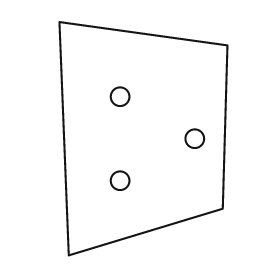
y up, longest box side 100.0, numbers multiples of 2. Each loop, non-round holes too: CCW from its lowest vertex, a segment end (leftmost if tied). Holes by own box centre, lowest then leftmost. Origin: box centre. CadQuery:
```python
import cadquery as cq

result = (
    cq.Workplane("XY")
    .moveTo(-32.0, -50.0)
    .lineTo(34.0, -30.0)
    .lineTo(36.0, 40.0)
    .lineTo(-36.0, 50.0)
    .close()
    .moveTo(-10.0, -18.0)
    .circle(4.0)
    .moveTo(22.0, 0.0)
    .circle(4.0)
    .moveTo(-10.0, 18.0)
    .circle(4.0)
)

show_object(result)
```